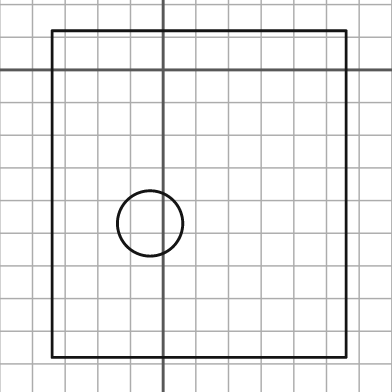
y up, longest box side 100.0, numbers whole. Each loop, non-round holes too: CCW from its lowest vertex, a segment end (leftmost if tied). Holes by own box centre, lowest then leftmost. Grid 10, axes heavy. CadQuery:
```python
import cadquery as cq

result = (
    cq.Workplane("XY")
    .moveTo(-34.0, -88.0)
    .lineTo(56.0, -88.0)
    .lineTo(56.0, 12.0)
    .lineTo(-34.0, 12.0)
    .close()
    .moveTo(-4.0, -47.0)
    .circle(10.0)
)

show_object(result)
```